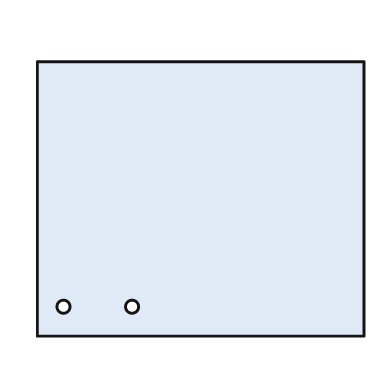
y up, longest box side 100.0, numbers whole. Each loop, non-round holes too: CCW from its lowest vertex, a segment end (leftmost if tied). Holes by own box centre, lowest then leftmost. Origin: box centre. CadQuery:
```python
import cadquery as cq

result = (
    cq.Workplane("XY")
    .moveTo(-50.0, -42.0)
    .lineTo(50.0, -42.0)
    .lineTo(50.0, 42.0)
    .lineTo(-50.0, 42.0)
    .close()
    .moveTo(-42.0, -33.0)
    .circle(2.0)
    .moveTo(-21.0, -33.0)
    .circle(2.0)
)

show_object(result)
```